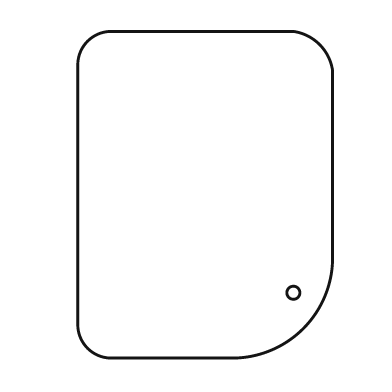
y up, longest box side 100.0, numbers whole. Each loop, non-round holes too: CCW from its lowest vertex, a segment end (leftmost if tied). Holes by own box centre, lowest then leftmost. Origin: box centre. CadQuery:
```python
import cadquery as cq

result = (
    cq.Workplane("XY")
    .moveTo(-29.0, -50.0)
    .lineTo(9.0, -50.0)
    .threePointArc((30.0, -41.0), (39.0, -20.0))
    .lineTo(39.0, 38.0)
    .threePointArc((35.0, 46.0), (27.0, 50.0))
    .lineTo(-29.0, 50.0)
    .threePointArc((-36.0, 47.0), (-39.0, 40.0))
    .lineTo(-39.0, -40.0)
    .threePointArc((-36.0, -47.0), (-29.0, -50.0))
    .close()
    .moveTo(27.0, -30.0)
    .circle(2.0)
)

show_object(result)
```